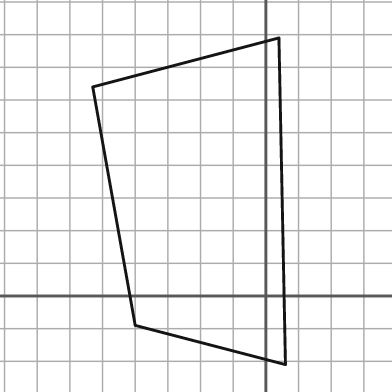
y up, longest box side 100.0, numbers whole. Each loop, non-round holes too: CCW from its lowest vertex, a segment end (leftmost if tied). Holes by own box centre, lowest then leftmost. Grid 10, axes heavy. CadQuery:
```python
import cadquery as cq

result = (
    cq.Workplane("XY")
    .moveTo(6.0, -21.0)
    .lineTo(4.0, 79.0)
    .lineTo(-53.0, 64.0)
    .lineTo(-40.0, -9.0)
    .close()
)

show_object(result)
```